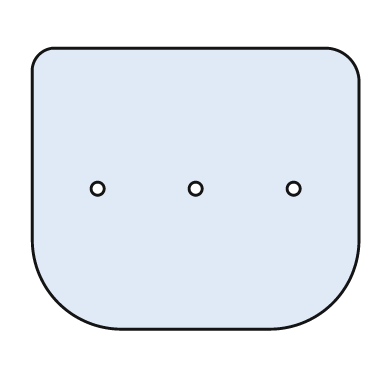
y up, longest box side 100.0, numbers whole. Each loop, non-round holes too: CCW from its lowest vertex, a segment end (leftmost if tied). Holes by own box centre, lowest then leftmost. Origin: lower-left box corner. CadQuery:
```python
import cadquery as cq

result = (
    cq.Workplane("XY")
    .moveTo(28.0, 0.0)
    .lineTo(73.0, 0.0)
    .threePointArc((92.0, 8.0), (100.0, 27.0))
    .lineTo(100.0, 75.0)
    .threePointArc((97.0, 83.0), (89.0, 86.0))
    .lineTo(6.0, 86.0)
    .threePointArc((2.0, 84.0), (0.0, 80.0))
    .lineTo(0.0, 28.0)
    .threePointArc((8.0, 8.0), (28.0, 0.0))
    .close()
    .moveTo(20.0, 43.0)
    .circle(2.0)
    .moveTo(50.0, 43.0)
    .circle(2.0)
    .moveTo(80.0, 43.0)
    .circle(2.0)
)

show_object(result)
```